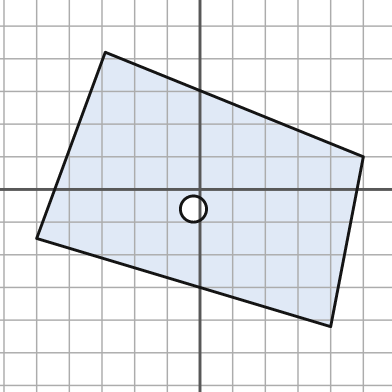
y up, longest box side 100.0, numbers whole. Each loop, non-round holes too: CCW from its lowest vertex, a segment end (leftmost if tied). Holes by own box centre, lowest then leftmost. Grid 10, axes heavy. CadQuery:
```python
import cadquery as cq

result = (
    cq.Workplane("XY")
    .moveTo(40.0, -42.0)
    .lineTo(50.0, 10.0)
    .lineTo(-29.0, 42.0)
    .lineTo(-50.0, -15.0)
    .close()
    .moveTo(-2.0, -6.0)
    .circle(4.0)
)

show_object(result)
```